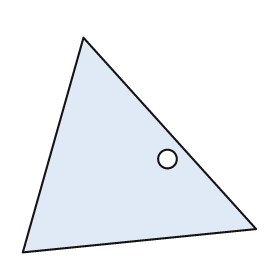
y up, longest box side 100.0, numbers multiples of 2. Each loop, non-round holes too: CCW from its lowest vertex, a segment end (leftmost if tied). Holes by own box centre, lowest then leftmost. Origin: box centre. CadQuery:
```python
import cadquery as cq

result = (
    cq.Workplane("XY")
    .moveTo(-50.0, -46.0)
    .lineTo(50.0, -36.0)
    .lineTo(-24.0, 46.0)
    .close()
    .moveTo(12.0, -6.0)
    .circle(4.0)
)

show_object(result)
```